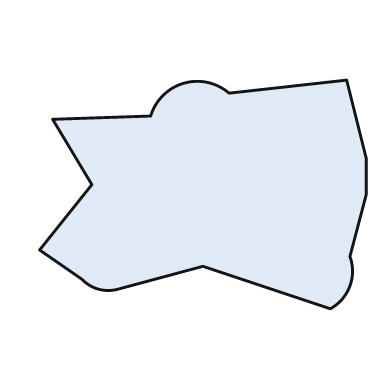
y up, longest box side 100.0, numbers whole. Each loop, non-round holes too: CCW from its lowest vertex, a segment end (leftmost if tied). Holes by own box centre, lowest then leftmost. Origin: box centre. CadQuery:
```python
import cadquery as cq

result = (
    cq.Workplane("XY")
    .moveTo(39.0, -35.0)
    .threePointArc((45.0, -28.0), (45.0, -19.0))
    .lineTo(50.0, 0.0)
    .lineTo(50.0, 11.0)
    .lineTo(44.0, 35.0)
    .lineTo(8.0, 31.0)
    .threePointArc((-6.0, 34.0), (-16.0, 24.0))
    .lineTo(-46.0, 23.0)
    .lineTo(-34.0, 3.0)
    .lineTo(-50.0, -17.0)
    .lineTo(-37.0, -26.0)
    .threePointArc((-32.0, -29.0), (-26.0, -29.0))
    .lineTo(0.0, -22.0)
    .close()
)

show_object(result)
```